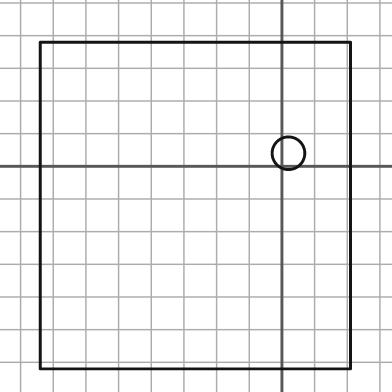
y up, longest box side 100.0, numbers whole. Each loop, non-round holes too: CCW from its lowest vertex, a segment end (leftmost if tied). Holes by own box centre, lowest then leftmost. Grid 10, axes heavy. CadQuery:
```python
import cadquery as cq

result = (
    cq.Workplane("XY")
    .moveTo(-74.0, -62.0)
    .lineTo(21.0, -62.0)
    .lineTo(21.0, 38.0)
    .lineTo(-74.0, 38.0)
    .close()
    .moveTo(2.0, 4.0)
    .circle(5.0)
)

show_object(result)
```